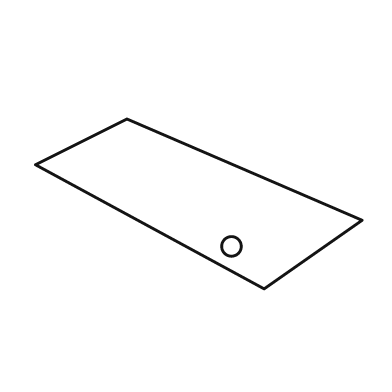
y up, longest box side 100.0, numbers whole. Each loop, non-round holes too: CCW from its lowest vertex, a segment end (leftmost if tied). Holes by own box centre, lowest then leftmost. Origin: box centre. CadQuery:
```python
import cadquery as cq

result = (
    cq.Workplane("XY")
    .moveTo(20.0, -26.0)
    .lineTo(50.0, -5.0)
    .lineTo(-22.0, 26.0)
    .lineTo(-50.0, 12.0)
    .close()
    .moveTo(10.0, -13.0)
    .circle(3.0)
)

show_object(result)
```